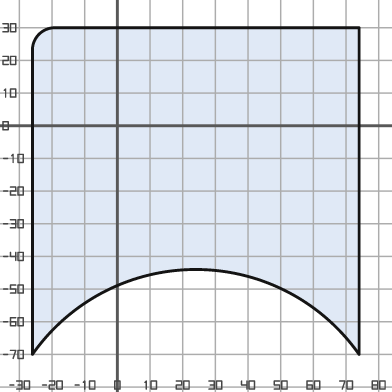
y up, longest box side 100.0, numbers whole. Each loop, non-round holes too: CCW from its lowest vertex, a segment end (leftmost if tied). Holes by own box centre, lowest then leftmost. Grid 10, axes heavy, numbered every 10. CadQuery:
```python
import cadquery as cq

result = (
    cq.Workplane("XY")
    .moveTo(-26.0, -70.0)
    .threePointArc((24.0, -44.0), (74.0, -70.0))
    .lineTo(74.0, 30.0)
    .lineTo(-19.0, 30.0)
    .threePointArc((-24.0, 28.0), (-26.0, 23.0))
    .close()
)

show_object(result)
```